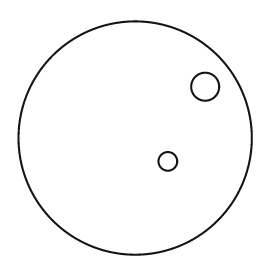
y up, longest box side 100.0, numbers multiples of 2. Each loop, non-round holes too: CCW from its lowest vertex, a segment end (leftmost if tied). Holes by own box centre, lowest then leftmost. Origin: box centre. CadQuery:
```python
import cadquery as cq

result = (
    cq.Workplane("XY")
    .moveTo(0.0, 0.0)
    .circle(50.0)
    .moveTo(14.0, -10.0)
    .circle(4.0)
    .moveTo(30.0, 22.0)
    .circle(6.0)
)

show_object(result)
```